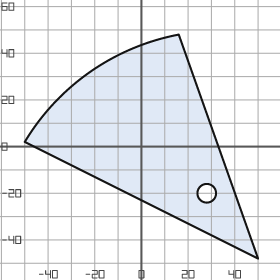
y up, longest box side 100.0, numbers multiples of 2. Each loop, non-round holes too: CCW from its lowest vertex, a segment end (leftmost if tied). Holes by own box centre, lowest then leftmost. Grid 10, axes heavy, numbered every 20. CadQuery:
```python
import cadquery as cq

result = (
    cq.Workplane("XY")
    .moveTo(50.0, -48.0)
    .lineTo(16.0, 48.0)
    .threePointArc((-22.0, 32.0), (-50.0, 2.0))
    .close()
    .moveTo(28.0, -20.0)
    .circle(4.0)
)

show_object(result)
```